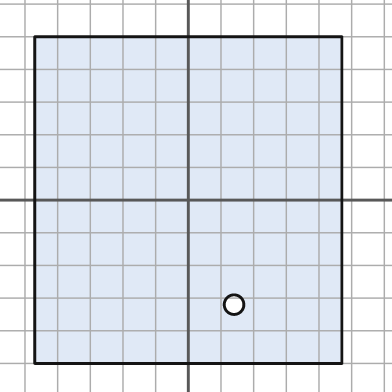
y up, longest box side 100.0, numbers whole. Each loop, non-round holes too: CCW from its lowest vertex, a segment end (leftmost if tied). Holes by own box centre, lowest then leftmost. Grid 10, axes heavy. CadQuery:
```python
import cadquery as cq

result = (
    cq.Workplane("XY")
    .moveTo(-47.0, -50.0)
    .lineTo(47.0, -50.0)
    .lineTo(47.0, 50.0)
    .lineTo(-47.0, 50.0)
    .close()
    .moveTo(14.0, -32.0)
    .circle(3.0)
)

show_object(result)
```